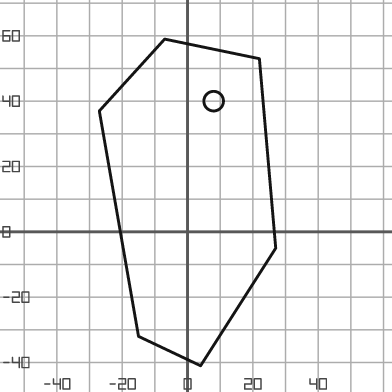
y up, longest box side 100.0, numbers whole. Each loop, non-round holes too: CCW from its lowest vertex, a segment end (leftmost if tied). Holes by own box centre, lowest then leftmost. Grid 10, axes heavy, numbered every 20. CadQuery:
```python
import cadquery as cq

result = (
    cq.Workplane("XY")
    .moveTo(4.0, -41.0)
    .lineTo(27.0, -5.0)
    .lineTo(22.0, 53.0)
    .lineTo(-7.0, 59.0)
    .lineTo(-27.0, 37.0)
    .lineTo(-15.0, -32.0)
    .close()
    .moveTo(8.0, 40.0)
    .circle(3.0)
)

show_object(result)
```